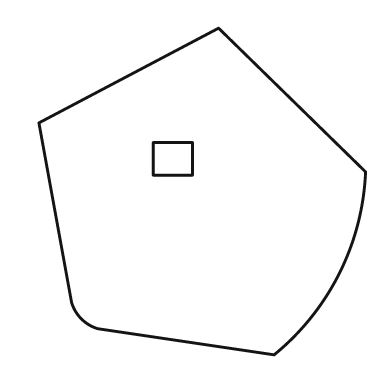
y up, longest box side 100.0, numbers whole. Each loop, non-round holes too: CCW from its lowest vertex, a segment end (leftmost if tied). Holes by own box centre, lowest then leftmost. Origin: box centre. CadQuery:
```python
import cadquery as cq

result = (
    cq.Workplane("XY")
    .moveTo(22.0, -50.0)
    .threePointArc((42.0, -25.0), (50.0, 6.0))
    .lineTo(5.0, 50.0)
    .lineTo(-50.0, 21.0)
    .lineTo(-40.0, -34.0)
    .threePointArc((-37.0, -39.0), (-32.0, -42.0))
    .close()
    .moveTo(-15.0, 5.0)
    .lineTo(-3.0, 5.0)
    .lineTo(-3.0, 15.0)
    .lineTo(-15.0, 15.0)
    .close()
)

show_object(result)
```